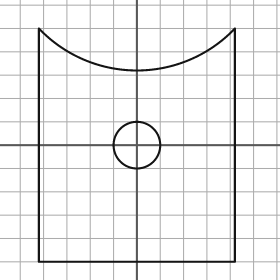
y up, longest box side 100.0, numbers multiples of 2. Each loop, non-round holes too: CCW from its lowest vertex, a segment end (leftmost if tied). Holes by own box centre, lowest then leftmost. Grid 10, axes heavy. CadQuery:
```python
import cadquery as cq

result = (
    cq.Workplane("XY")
    .moveTo(-42.0, -50.0)
    .lineTo(42.0, -50.0)
    .lineTo(42.0, 50.0)
    .threePointArc((0.0, 32.0), (-42.0, 50.0))
    .close()
    .moveTo(0.0, 0.0)
    .circle(10.0)
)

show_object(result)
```